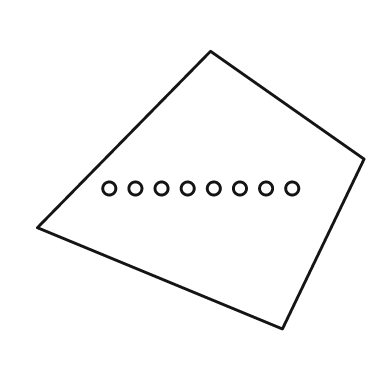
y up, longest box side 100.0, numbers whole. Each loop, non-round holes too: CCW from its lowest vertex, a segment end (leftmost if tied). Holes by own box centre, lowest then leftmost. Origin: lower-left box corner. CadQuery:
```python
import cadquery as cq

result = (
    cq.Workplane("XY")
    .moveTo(75.0, 0.0)
    .lineTo(100.0, 52.0)
    .lineTo(53.0, 85.0)
    .lineTo(0.0, 31.0)
    .close()
    .moveTo(22.0, 43.0)
    .circle(2.0)
    .moveTo(30.0, 43.0)
    .circle(2.0)
    .moveTo(38.0, 43.0)
    .circle(2.0)
    .moveTo(46.0, 43.0)
    .circle(2.0)
    .moveTo(54.0, 43.0)
    .circle(2.0)
    .moveTo(62.0, 43.0)
    .circle(2.0)
    .moveTo(70.0, 43.0)
    .circle(2.0)
    .moveTo(78.0, 43.0)
    .circle(2.0)
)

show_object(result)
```